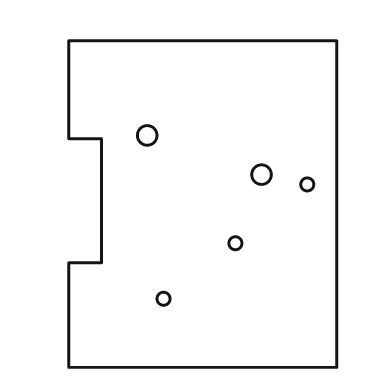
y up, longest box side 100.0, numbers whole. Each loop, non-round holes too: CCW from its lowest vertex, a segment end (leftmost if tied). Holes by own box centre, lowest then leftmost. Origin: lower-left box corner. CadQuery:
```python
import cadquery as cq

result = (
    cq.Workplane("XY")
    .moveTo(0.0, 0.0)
    .lineTo(82.0, 0.0)
    .lineTo(82.0, 100.0)
    .lineTo(0.0, 100.0)
    .lineTo(0.0, 70.0)
    .lineTo(10.0, 70.0)
    .lineTo(10.0, 32.0)
    .lineTo(0.0, 32.0)
    .close()
    .moveTo(29.0, 21.0)
    .circle(2.0)
    .moveTo(51.0, 38.0)
    .circle(2.0)
    .moveTo(73.0, 56.0)
    .circle(2.0)
    .moveTo(59.0, 59.0)
    .circle(3.0)
    .moveTo(24.0, 71.0)
    .circle(3.0)
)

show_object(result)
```